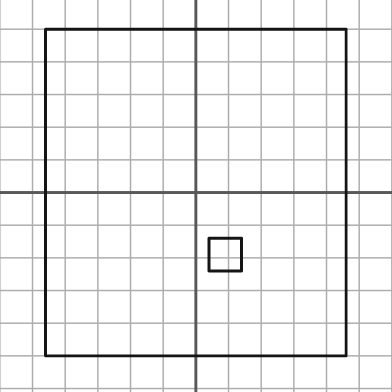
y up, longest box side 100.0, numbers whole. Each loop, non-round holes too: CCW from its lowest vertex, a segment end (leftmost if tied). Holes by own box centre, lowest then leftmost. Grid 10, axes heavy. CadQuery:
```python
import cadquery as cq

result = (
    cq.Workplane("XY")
    .moveTo(-46.0, -50.0)
    .lineTo(46.0, -50.0)
    .lineTo(46.0, 50.0)
    .lineTo(-46.0, 50.0)
    .close()
    .moveTo(4.0, -24.0)
    .lineTo(14.0, -24.0)
    .lineTo(14.0, -14.0)
    .lineTo(4.0, -14.0)
    .close()
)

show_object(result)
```